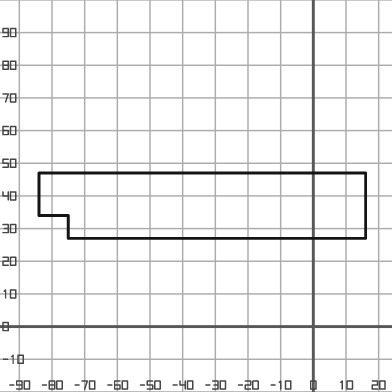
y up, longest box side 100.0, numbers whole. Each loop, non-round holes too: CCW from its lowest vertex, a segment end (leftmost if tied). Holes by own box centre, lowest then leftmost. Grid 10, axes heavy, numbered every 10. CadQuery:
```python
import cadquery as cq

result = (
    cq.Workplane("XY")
    .moveTo(-75.0, 27.0)
    .lineTo(16.0, 27.0)
    .lineTo(16.0, 47.0)
    .lineTo(-84.0, 47.0)
    .lineTo(-84.0, 34.0)
    .lineTo(-75.0, 34.0)
    .close()
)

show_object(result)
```